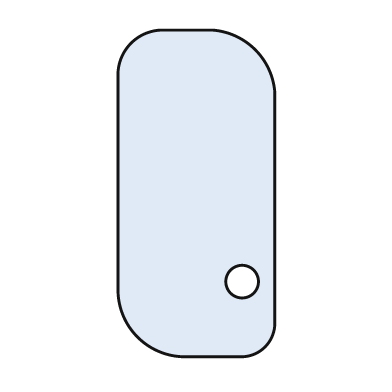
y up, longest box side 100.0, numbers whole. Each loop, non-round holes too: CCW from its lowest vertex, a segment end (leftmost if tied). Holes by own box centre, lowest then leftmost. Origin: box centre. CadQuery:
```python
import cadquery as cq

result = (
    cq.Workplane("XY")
    .moveTo(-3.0, -50.0)
    .lineTo(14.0, -50.0)
    .threePointArc((21.0, -47.0), (24.0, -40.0))
    .lineTo(24.0, 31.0)
    .threePointArc((18.0, 44.0), (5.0, 50.0))
    .lineTo(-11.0, 50.0)
    .threePointArc((-20.0, 46.0), (-24.0, 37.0))
    .lineTo(-24.0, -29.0)
    .threePointArc((-18.0, -44.0), (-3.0, -50.0))
    .close()
    .moveTo(14.0, -27.0)
    .circle(5.0)
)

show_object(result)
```